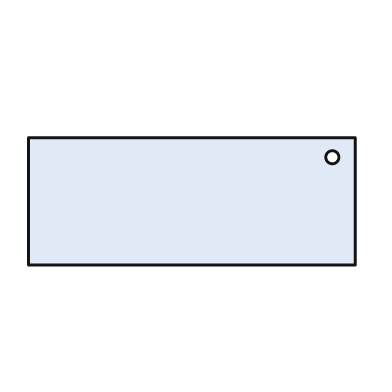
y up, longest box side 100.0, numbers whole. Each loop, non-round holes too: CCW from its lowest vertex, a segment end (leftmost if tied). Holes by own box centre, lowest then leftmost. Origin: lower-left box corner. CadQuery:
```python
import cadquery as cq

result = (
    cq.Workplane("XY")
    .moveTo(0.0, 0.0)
    .lineTo(100.0, 0.0)
    .lineTo(100.0, 39.0)
    .lineTo(0.0, 39.0)
    .close()
    .moveTo(93.0, 33.0)
    .circle(2.0)
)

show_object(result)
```